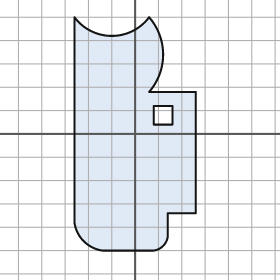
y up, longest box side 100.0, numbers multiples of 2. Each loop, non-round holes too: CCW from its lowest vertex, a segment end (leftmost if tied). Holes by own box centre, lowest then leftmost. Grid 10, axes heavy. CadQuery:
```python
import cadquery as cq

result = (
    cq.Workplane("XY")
    .moveTo(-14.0, -50.0)
    .lineTo(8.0, -50.0)
    .threePointArc((12.0, -48.0), (14.0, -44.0))
    .lineTo(14.0, -34.0)
    .lineTo(26.0, -34.0)
    .lineTo(26.0, 18.0)
    .lineTo(6.0, 18.0)
    .threePointArc((12.0, 34.0), (6.0, 50.0))
    .threePointArc((-10.0, 42.0), (-26.0, 50.0))
    .lineTo(-26.0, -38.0)
    .threePointArc((-22.0, -46.0), (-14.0, -50.0))
    .close()
    .moveTo(8.0, 4.0)
    .lineTo(16.0, 4.0)
    .lineTo(16.0, 12.0)
    .lineTo(8.0, 12.0)
    .close()
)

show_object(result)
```